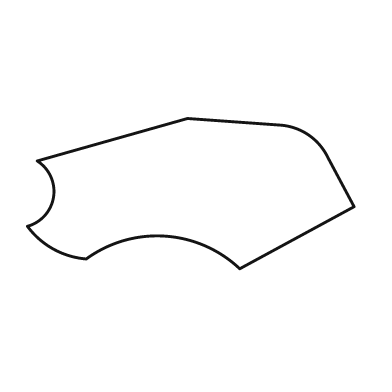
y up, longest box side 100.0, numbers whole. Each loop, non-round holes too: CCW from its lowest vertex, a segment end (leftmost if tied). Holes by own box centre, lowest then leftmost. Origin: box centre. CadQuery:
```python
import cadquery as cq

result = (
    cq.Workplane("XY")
    .moveTo(15.0, -23.0)
    .lineTo(50.0, -4.0)
    .lineTo(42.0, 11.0)
    .threePointArc((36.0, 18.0), (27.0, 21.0))
    .lineTo(-1.0, 23.0)
    .lineTo(-47.0, 10.0)
    .threePointArc((-42.0, -1.0), (-50.0, -10.0))
    .threePointArc((-42.0, -17.0), (-32.0, -20.0))
    .threePointArc((-8.0, -13.0), (15.0, -23.0))
    .close()
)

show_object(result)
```